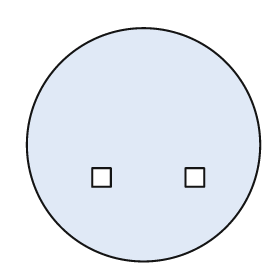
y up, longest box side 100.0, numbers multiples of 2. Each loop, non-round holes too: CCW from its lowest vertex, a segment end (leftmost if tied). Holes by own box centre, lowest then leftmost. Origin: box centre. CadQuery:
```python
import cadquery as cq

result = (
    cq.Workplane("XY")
    .moveTo(0.0, 0.0)
    .circle(50.0)
    .moveTo(-22.0, -18.0)
    .lineTo(-14.0, -18.0)
    .lineTo(-14.0, -10.0)
    .lineTo(-22.0, -10.0)
    .close()
    .moveTo(18.0, -18.0)
    .lineTo(26.0, -18.0)
    .lineTo(26.0, -10.0)
    .lineTo(18.0, -10.0)
    .close()
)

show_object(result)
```